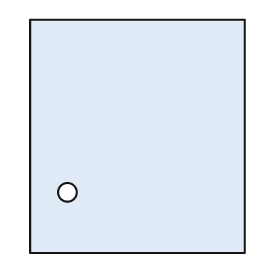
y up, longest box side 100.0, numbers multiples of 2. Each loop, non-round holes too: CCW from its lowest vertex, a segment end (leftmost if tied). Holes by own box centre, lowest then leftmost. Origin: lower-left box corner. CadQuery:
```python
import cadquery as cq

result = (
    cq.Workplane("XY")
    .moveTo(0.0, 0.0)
    .lineTo(92.0, 0.0)
    .lineTo(92.0, 100.0)
    .lineTo(0.0, 100.0)
    .close()
    .moveTo(16.0, 26.0)
    .circle(4.0)
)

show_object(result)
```